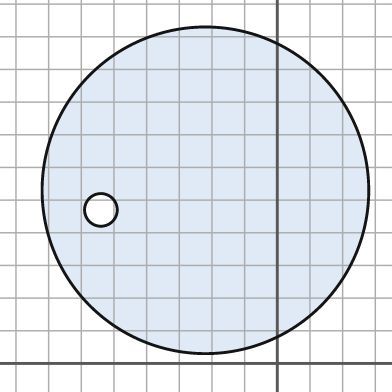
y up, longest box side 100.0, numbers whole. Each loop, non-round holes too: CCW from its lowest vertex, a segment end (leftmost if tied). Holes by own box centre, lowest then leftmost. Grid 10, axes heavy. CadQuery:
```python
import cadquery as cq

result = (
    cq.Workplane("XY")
    .moveTo(-22.0, 53.0)
    .circle(50.0)
    .moveTo(-54.0, 47.0)
    .circle(5.0)
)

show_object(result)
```